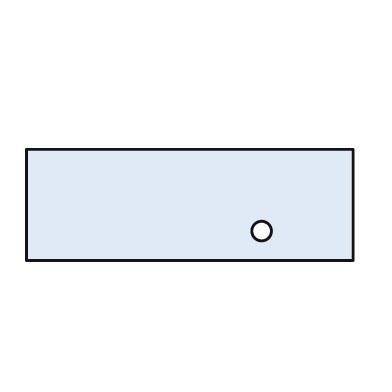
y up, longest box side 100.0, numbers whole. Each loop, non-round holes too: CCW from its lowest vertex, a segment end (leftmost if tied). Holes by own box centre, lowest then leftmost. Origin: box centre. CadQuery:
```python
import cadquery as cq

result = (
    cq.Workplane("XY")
    .moveTo(-50.0, -17.0)
    .lineTo(50.0, -17.0)
    .lineTo(50.0, 17.0)
    .lineTo(-50.0, 17.0)
    .close()
    .moveTo(22.0, -8.0)
    .circle(3.0)
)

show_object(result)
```